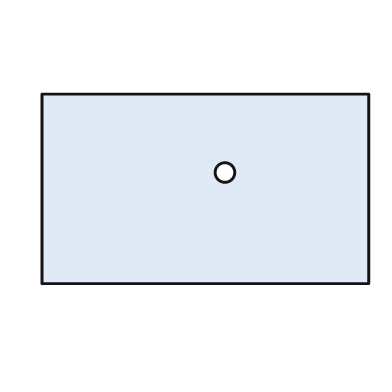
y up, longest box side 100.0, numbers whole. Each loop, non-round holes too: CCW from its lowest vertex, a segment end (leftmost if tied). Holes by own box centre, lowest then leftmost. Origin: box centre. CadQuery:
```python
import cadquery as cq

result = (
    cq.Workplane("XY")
    .moveTo(-50.0, -29.0)
    .lineTo(50.0, -29.0)
    .lineTo(50.0, 29.0)
    .lineTo(-50.0, 29.0)
    .close()
    .moveTo(6.0, 5.0)
    .circle(3.0)
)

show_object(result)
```